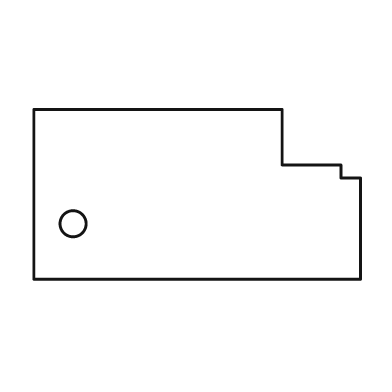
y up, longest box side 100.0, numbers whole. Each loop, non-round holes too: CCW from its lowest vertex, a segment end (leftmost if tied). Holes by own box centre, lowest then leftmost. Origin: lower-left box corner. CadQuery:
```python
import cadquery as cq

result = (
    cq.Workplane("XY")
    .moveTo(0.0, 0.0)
    .lineTo(100.0, 0.0)
    .lineTo(100.0, 31.0)
    .lineTo(94.0, 31.0)
    .lineTo(94.0, 35.0)
    .lineTo(76.0, 35.0)
    .lineTo(76.0, 52.0)
    .lineTo(0.0, 52.0)
    .close()
    .moveTo(12.0, 17.0)
    .circle(4.0)
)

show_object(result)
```